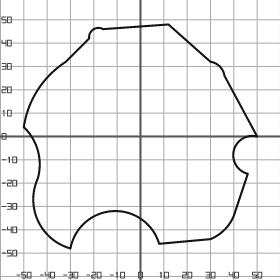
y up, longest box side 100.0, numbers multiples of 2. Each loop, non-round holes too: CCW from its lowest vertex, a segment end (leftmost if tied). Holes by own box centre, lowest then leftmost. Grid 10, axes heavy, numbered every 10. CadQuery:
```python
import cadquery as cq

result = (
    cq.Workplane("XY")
    .moveTo(-30.0, -48.0)
    .threePointArc((-12.0, -32.0), (8.0, -46.0))
    .lineTo(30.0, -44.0)
    .threePointArc((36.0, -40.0), (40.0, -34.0))
    .lineTo(46.0, -16.0)
    .threePointArc((40.0, -6.0), (50.0, 0.0))
    .lineTo(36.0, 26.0)
    .threePointArc((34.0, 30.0), (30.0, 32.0))
    .lineTo(12.0, 48.0)
    .lineTo(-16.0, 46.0)
    .threePointArc((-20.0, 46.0), (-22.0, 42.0))
    .lineTo(-32.0, 32.0)
    .threePointArc((-44.0, 20.0), (-50.0, 4.0))
    .threePointArc((-44.0, -6.0), (-44.0, -18.0))
    .threePointArc((-44.0, -36.0), (-30.0, -48.0))
    .close()
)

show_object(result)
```